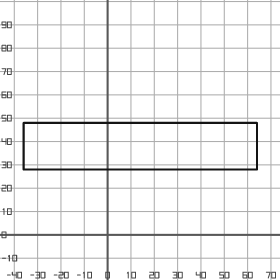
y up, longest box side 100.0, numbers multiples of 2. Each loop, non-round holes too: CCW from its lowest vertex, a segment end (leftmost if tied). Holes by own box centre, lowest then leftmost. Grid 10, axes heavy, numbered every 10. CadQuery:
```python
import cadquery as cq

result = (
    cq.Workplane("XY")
    .moveTo(-36.0, 28.0)
    .lineTo(64.0, 28.0)
    .lineTo(64.0, 48.0)
    .lineTo(-36.0, 48.0)
    .close()
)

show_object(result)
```